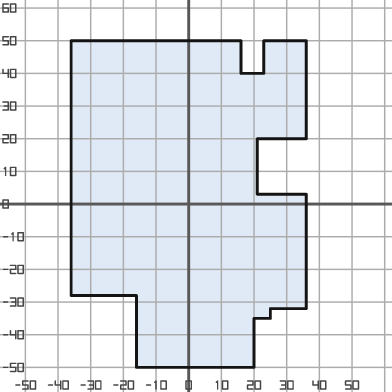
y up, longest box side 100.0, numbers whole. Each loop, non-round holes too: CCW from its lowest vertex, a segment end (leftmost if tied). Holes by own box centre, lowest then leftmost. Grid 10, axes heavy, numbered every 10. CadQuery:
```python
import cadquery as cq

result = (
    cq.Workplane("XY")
    .moveTo(-16.0, -50.0)
    .lineTo(20.0, -50.0)
    .lineTo(20.0, -35.0)
    .lineTo(25.0, -35.0)
    .lineTo(25.0, -32.0)
    .lineTo(36.0, -32.0)
    .lineTo(36.0, 3.0)
    .lineTo(21.0, 3.0)
    .lineTo(21.0, 20.0)
    .lineTo(36.0, 20.0)
    .lineTo(36.0, 50.0)
    .lineTo(23.0, 50.0)
    .lineTo(23.0, 40.0)
    .lineTo(16.0, 40.0)
    .lineTo(16.0, 50.0)
    .lineTo(-36.0, 50.0)
    .lineTo(-36.0, -28.0)
    .lineTo(-16.0, -28.0)
    .close()
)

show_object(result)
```